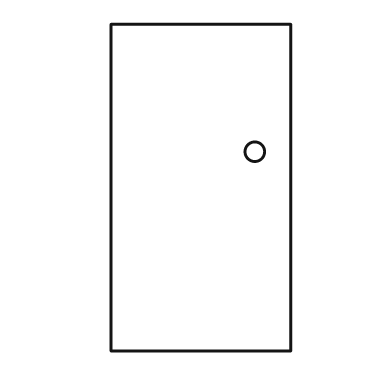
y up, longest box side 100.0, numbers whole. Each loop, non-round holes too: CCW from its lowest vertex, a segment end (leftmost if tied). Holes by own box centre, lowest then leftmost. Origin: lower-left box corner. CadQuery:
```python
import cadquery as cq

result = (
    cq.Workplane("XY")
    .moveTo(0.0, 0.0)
    .lineTo(55.0, 0.0)
    .lineTo(55.0, 100.0)
    .lineTo(0.0, 100.0)
    .close()
    .moveTo(44.0, 61.0)
    .circle(3.0)
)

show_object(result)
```